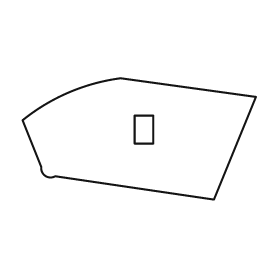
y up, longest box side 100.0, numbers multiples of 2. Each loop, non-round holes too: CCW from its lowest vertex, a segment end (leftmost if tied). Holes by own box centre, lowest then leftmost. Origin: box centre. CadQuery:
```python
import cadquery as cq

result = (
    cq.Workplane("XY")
    .moveTo(32.0, -26.0)
    .lineTo(50.0, 18.0)
    .lineTo(-8.0, 26.0)
    .threePointArc((-30.0, 20.0), (-50.0, 8.0))
    .lineTo(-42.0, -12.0)
    .threePointArc((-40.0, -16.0), (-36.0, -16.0))
    .close()
    .moveTo(-2.0, -2.0)
    .lineTo(6.0, -2.0)
    .lineTo(6.0, 10.0)
    .lineTo(-2.0, 10.0)
    .close()
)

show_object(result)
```